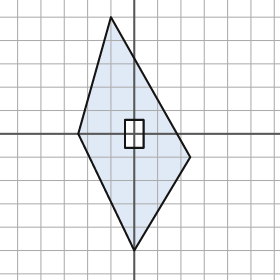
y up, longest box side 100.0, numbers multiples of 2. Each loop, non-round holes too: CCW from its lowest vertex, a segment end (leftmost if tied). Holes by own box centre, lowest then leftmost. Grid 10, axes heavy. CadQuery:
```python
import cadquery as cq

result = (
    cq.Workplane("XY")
    .moveTo(0.0, -50.0)
    .lineTo(24.0, -10.0)
    .lineTo(-10.0, 50.0)
    .lineTo(-24.0, 0.0)
    .close()
    .moveTo(-4.0, -6.0)
    .lineTo(4.0, -6.0)
    .lineTo(4.0, 6.0)
    .lineTo(-4.0, 6.0)
    .close()
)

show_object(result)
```